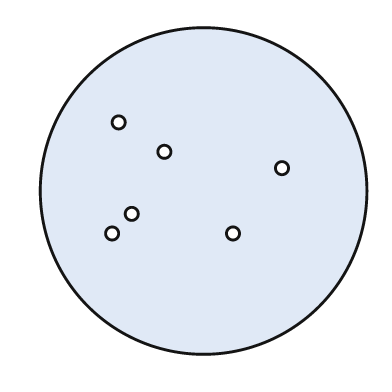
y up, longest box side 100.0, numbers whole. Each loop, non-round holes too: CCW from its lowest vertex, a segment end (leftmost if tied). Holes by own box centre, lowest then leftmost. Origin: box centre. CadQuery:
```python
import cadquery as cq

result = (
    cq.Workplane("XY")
    .moveTo(0.0, 0.0)
    .circle(50.0)
    .moveTo(-28.0, -13.0)
    .circle(2.0)
    .moveTo(9.0, -13.0)
    .circle(2.0)
    .moveTo(-22.0, -7.0)
    .circle(2.0)
    .moveTo(24.0, 7.0)
    .circle(2.0)
    .moveTo(-12.0, 12.0)
    .circle(2.0)
    .moveTo(-26.0, 21.0)
    .circle(2.0)
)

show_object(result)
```